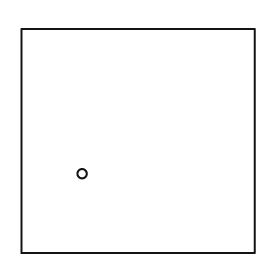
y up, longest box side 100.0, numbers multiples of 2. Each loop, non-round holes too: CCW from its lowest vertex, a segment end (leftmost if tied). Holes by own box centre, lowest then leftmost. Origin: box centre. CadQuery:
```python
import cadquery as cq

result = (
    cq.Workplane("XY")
    .moveTo(-50.0, -48.0)
    .lineTo(50.0, -48.0)
    .lineTo(50.0, 48.0)
    .lineTo(-50.0, 48.0)
    .close()
    .moveTo(-24.0, -14.0)
    .circle(2.0)
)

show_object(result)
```